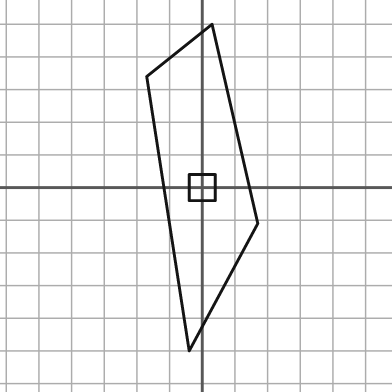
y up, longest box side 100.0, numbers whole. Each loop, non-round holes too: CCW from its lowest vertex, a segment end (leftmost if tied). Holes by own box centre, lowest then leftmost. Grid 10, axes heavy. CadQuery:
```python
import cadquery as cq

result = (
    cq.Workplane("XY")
    .moveTo(-4.0, -50.0)
    .lineTo(17.0, -11.0)
    .lineTo(3.0, 50.0)
    .lineTo(-17.0, 34.0)
    .close()
    .moveTo(-4.0, -4.0)
    .lineTo(4.0, -4.0)
    .lineTo(4.0, 4.0)
    .lineTo(-4.0, 4.0)
    .close()
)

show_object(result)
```